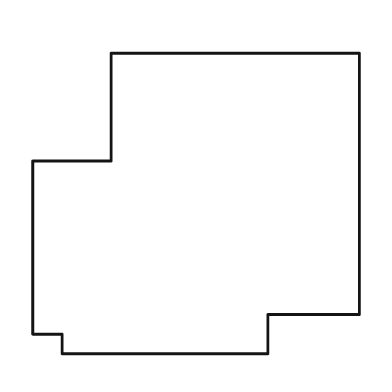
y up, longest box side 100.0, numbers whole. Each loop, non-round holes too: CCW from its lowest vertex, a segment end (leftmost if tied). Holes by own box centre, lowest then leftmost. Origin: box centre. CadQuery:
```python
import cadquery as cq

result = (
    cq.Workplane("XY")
    .moveTo(-41.0, -46.0)
    .lineTo(22.0, -46.0)
    .lineTo(22.0, -34.0)
    .lineTo(50.0, -34.0)
    .lineTo(50.0, 46.0)
    .lineTo(-26.0, 46.0)
    .lineTo(-26.0, 13.0)
    .lineTo(-50.0, 13.0)
    .lineTo(-50.0, -40.0)
    .lineTo(-41.0, -40.0)
    .close()
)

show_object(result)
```